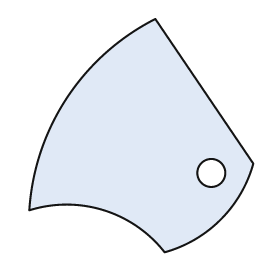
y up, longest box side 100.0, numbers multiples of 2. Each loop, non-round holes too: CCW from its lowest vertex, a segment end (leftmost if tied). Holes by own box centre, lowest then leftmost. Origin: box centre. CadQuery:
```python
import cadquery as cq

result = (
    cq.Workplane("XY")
    .moveTo(10.0, -50.0)
    .threePointArc((34.0, -36.0), (48.0, -12.0))
    .lineTo(6.0, 50.0)
    .threePointArc((-32.0, 16.0), (-48.0, -32.0))
    .threePointArc((-16.0, -32.0), (10.0, -50.0))
    .close()
    .moveTo(30.0, -16.0)
    .circle(6.0)
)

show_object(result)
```